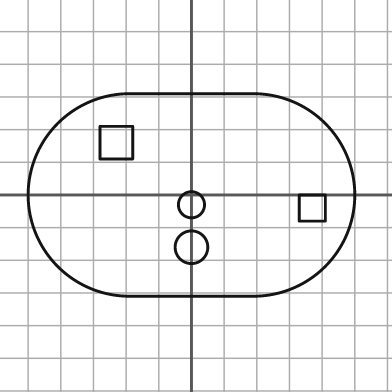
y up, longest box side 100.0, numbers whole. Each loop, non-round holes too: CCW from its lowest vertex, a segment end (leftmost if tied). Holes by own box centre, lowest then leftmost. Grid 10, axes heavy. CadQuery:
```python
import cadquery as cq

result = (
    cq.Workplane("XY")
    .moveTo(-19.0, -31.0)
    .lineTo(19.0, -31.0)
    .threePointArc((50.0, 0.0), (19.0, 31.0))
    .lineTo(-19.0, 31.0)
    .threePointArc((-50.0, 0.0), (-19.0, -31.0))
    .close()
    .moveTo(0.0, -16.0)
    .circle(5.0)
    .moveTo(33.0, -8.0)
    .lineTo(41.0, -8.0)
    .lineTo(41.0, 0.0)
    .lineTo(33.0, 0.0)
    .close()
    .moveTo(0.0, -3.0)
    .circle(4.0)
    .moveTo(-28.0, 11.0)
    .lineTo(-18.0, 11.0)
    .lineTo(-18.0, 21.0)
    .lineTo(-28.0, 21.0)
    .close()
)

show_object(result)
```